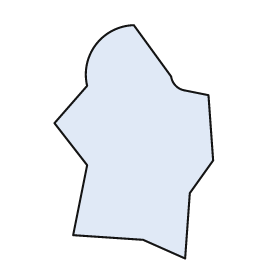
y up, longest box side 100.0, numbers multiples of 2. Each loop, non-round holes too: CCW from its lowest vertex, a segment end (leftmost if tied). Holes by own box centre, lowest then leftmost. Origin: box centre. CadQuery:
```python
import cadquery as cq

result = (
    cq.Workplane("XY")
    .moveTo(22.0, -50.0)
    .lineTo(24.0, -22.0)
    .lineTo(34.0, -8.0)
    .lineTo(32.0, 20.0)
    .lineTo(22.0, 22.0)
    .threePointArc((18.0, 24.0), (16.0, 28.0))
    .lineTo(0.0, 50.0)
    .threePointArc((-16.0, 42.0), (-20.0, 24.0))
    .lineTo(-34.0, 8.0)
    .lineTo(-20.0, -10.0)
    .lineTo(-26.0, -40.0)
    .lineTo(4.0, -42.0)
    .close()
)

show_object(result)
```